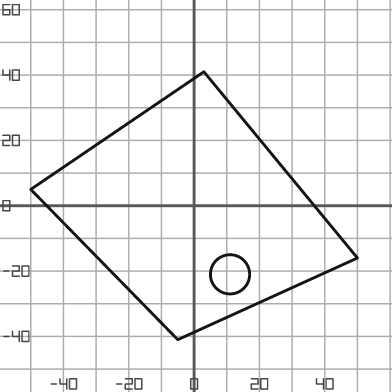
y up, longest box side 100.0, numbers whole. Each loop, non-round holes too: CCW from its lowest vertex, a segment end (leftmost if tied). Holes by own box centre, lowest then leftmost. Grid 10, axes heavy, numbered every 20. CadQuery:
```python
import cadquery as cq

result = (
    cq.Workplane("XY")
    .moveTo(-5.0, -41.0)
    .lineTo(50.0, -16.0)
    .lineTo(3.0, 41.0)
    .lineTo(-50.0, 5.0)
    .close()
    .moveTo(11.0, -21.0)
    .circle(6.0)
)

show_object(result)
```